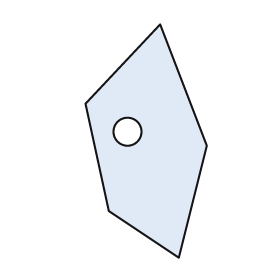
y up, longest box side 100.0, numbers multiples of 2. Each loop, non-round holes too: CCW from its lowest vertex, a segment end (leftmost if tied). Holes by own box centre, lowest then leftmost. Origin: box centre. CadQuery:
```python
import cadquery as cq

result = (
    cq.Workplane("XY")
    .moveTo(14.0, -50.0)
    .lineTo(26.0, -2.0)
    .lineTo(6.0, 50.0)
    .lineTo(-26.0, 16.0)
    .lineTo(-16.0, -30.0)
    .close()
    .moveTo(-8.0, 4.0)
    .circle(6.0)
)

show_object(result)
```